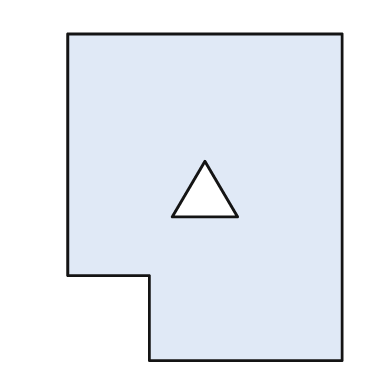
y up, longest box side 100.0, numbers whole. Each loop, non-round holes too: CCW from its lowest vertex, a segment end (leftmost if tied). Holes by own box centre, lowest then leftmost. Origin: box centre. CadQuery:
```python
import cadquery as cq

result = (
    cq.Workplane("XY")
    .moveTo(-17.0, -50.0)
    .lineTo(42.0, -50.0)
    .lineTo(42.0, 50.0)
    .lineTo(-42.0, 50.0)
    .lineTo(-42.0, -24.0)
    .lineTo(-17.0, -24.0)
    .close()
    .moveTo(-10.0, -6.0)
    .lineTo(10.0, -6.0)
    .lineTo(0.0, 11.0)
    .close()
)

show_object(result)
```